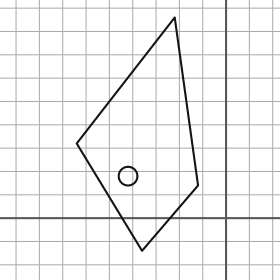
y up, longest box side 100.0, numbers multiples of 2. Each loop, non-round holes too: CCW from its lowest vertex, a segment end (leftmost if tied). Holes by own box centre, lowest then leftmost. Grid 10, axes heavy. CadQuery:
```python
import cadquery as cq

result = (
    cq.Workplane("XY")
    .moveTo(-36.0, -14.0)
    .lineTo(-12.0, 14.0)
    .lineTo(-22.0, 86.0)
    .lineTo(-64.0, 32.0)
    .close()
    .moveTo(-42.0, 18.0)
    .circle(4.0)
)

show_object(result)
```